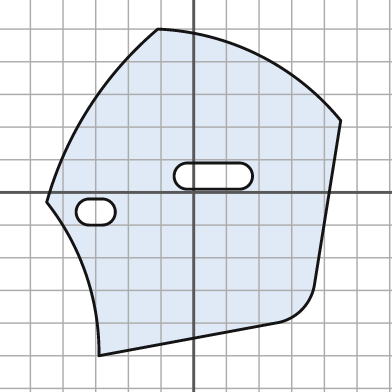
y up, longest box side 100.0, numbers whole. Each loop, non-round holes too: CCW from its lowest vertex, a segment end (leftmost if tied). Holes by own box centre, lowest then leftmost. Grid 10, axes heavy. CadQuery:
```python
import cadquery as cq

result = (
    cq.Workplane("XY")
    .moveTo(-29.0, -50.0)
    .lineTo(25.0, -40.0)
    .threePointArc((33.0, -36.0), (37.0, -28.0))
    .lineTo(45.0, 22.0)
    .threePointArc((20.0, 42.0), (-11.0, 50.0))
    .threePointArc((-32.0, 26.0), (-45.0, -3.0))
    .threePointArc((-33.0, -25.0), (-29.0, -50.0))
    .close()
    .moveTo(-32.0, -10.0)
    .lineTo(-28.0, -10.0)
    .threePointArc((-24.0, -6.0), (-28.0, -2.0))
    .lineTo(-32.0, -2.0)
    .threePointArc((-36.0, -6.0), (-32.0, -10.0))
    .close()
    .moveTo(-2.0, 1.0)
    .lineTo(14.0, 1.0)
    .threePointArc((18.0, 5.0), (14.0, 9.0))
    .lineTo(-2.0, 9.0)
    .threePointArc((-6.0, 5.0), (-2.0, 1.0))
    .close()
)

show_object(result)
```